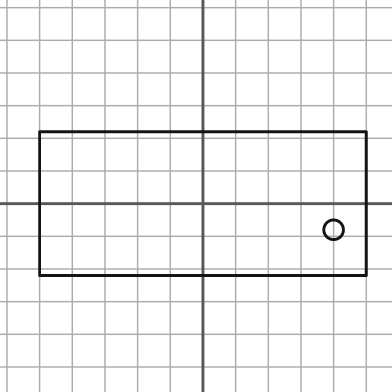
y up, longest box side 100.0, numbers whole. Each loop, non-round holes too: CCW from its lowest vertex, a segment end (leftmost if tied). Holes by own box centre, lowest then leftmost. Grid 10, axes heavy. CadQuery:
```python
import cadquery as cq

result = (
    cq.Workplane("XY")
    .moveTo(-50.0, -22.0)
    .lineTo(50.0, -22.0)
    .lineTo(50.0, 22.0)
    .lineTo(-50.0, 22.0)
    .close()
    .moveTo(40.0, -8.0)
    .circle(3.0)
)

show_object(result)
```